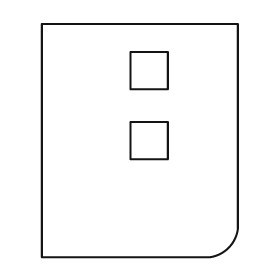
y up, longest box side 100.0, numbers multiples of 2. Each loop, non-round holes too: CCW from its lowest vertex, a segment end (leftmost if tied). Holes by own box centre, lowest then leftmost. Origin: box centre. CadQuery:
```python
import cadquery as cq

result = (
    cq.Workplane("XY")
    .moveTo(-42.0, -50.0)
    .lineTo(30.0, -50.0)
    .threePointArc((38.0, -46.0), (42.0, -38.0))
    .lineTo(42.0, 50.0)
    .lineTo(-42.0, 50.0)
    .close()
    .moveTo(-4.0, -8.0)
    .lineTo(12.0, -8.0)
    .lineTo(12.0, 8.0)
    .lineTo(-4.0, 8.0)
    .close()
    .moveTo(-4.0, 22.0)
    .lineTo(12.0, 22.0)
    .lineTo(12.0, 38.0)
    .lineTo(-4.0, 38.0)
    .close()
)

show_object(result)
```